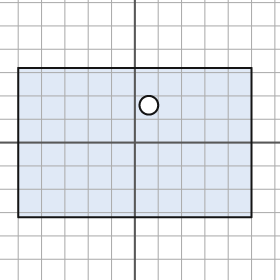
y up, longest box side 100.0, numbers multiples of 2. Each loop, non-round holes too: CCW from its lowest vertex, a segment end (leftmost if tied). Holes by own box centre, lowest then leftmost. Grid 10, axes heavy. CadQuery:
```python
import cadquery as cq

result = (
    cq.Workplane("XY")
    .moveTo(-50.0, -32.0)
    .lineTo(50.0, -32.0)
    .lineTo(50.0, 32.0)
    .lineTo(-50.0, 32.0)
    .close()
    .moveTo(6.0, 16.0)
    .circle(4.0)
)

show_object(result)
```